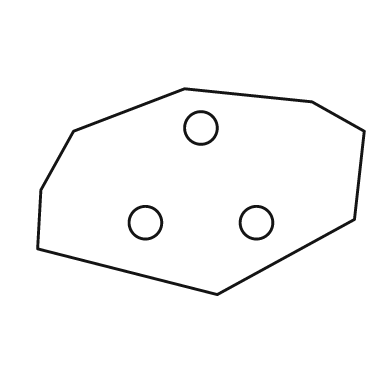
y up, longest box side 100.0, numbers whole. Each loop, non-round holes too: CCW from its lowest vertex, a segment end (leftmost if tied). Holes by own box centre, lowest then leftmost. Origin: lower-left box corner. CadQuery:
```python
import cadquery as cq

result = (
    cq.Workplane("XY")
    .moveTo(55.0, 0.0)
    .lineTo(97.0, 23.0)
    .lineTo(100.0, 50.0)
    .lineTo(84.0, 59.0)
    .lineTo(45.0, 63.0)
    .lineTo(11.0, 50.0)
    .lineTo(1.0, 32.0)
    .lineTo(0.0, 14.0)
    .close()
    .moveTo(33.0, 22.0)
    .circle(5.0)
    .moveTo(67.0, 22.0)
    .circle(5.0)
    .moveTo(50.0, 51.0)
    .circle(5.0)
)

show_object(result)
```